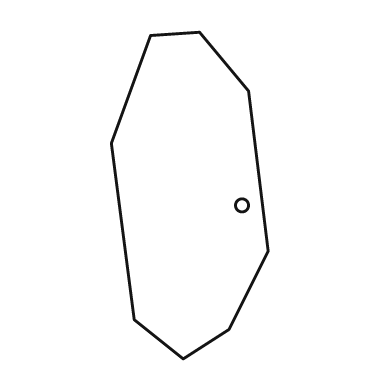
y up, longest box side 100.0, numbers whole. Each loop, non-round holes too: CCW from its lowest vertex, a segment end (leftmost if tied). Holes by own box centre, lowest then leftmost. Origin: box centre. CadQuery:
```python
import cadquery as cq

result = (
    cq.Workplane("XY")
    .moveTo(-2.0, -50.0)
    .lineTo(12.0, -41.0)
    .lineTo(24.0, -17.0)
    .lineTo(18.0, 32.0)
    .lineTo(3.0, 50.0)
    .lineTo(-12.0, 49.0)
    .lineTo(-24.0, 16.0)
    .lineTo(-17.0, -38.0)
    .close()
    .moveTo(16.0, -3.0)
    .circle(2.0)
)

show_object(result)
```